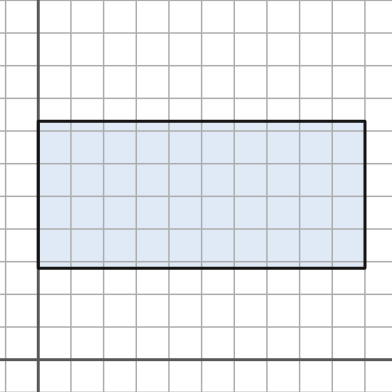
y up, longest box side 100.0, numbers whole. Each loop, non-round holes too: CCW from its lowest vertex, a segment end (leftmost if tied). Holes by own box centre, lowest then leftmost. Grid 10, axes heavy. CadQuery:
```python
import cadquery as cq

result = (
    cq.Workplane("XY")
    .moveTo(0.0, 28.0)
    .lineTo(100.0, 28.0)
    .lineTo(100.0, 73.0)
    .lineTo(0.0, 73.0)
    .close()
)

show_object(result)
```